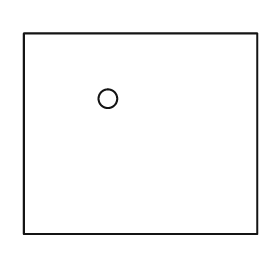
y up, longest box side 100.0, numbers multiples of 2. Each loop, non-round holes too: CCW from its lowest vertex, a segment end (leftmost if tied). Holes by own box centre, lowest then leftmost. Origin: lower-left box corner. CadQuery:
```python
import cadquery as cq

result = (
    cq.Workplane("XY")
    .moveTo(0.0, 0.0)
    .lineTo(100.0, 0.0)
    .lineTo(100.0, 86.0)
    .lineTo(0.0, 86.0)
    .close()
    .moveTo(36.0, 58.0)
    .circle(4.0)
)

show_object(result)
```